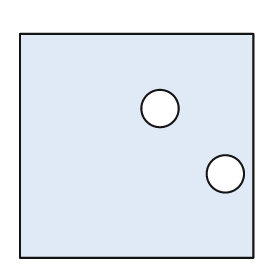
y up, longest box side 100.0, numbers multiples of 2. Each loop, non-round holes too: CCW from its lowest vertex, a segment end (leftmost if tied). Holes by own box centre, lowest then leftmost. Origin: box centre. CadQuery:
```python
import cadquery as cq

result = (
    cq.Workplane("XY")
    .moveTo(-50.0, -48.0)
    .lineTo(50.0, -48.0)
    .lineTo(50.0, 48.0)
    .lineTo(-50.0, 48.0)
    .close()
    .moveTo(38.0, -12.0)
    .circle(8.0)
    .moveTo(10.0, 16.0)
    .circle(8.0)
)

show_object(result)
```